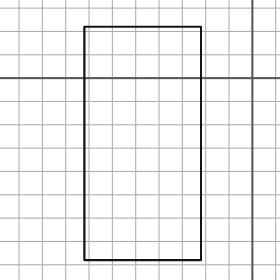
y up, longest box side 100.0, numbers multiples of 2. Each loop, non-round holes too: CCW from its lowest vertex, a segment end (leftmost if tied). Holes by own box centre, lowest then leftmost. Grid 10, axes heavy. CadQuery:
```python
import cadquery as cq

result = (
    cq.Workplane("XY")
    .moveTo(-72.0, -78.0)
    .lineTo(-22.0, -78.0)
    .lineTo(-22.0, 22.0)
    .lineTo(-72.0, 22.0)
    .close()
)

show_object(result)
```